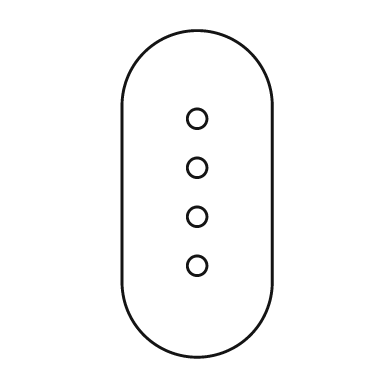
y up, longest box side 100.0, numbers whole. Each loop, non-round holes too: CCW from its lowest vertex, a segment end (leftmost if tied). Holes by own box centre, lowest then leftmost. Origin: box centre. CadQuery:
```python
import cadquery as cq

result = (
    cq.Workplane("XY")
    .moveTo(-23.0, -27.0)
    .threePointArc((0.0, -50.0), (23.0, -27.0))
    .lineTo(23.0, 27.0)
    .threePointArc((0.0, 50.0), (-23.0, 27.0))
    .close()
    .moveTo(0.0, -22.0)
    .circle(3.0)
    .moveTo(0.0, -7.0)
    .circle(3.0)
    .moveTo(0.0, 8.0)
    .circle(3.0)
    .moveTo(0.0, 23.0)
    .circle(3.0)
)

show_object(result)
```